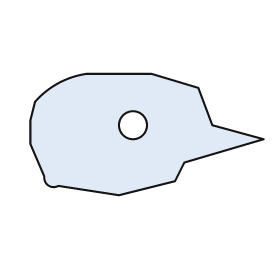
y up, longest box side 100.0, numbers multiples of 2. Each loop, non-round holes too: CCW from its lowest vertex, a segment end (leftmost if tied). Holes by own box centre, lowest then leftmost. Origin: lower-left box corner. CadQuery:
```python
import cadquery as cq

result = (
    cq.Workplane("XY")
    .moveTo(38.0, 0.0)
    .lineTo(62.0, 6.0)
    .lineTo(66.0, 14.0)
    .lineTo(100.0, 24.0)
    .lineTo(78.0, 30.0)
    .lineTo(72.0, 46.0)
    .lineTo(52.0, 52.0)
    .lineTo(24.0, 52.0)
    .threePointArc((12.0, 48.0), (2.0, 40.0))
    .lineTo(0.0, 32.0)
    .lineTo(0.0, 22.0)
    .lineTo(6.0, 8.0)
    .threePointArc((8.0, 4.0), (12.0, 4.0))
    .close()
    .moveTo(44.0, 30.0)
    .circle(6.0)
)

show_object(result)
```